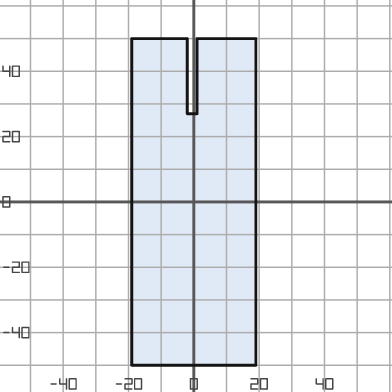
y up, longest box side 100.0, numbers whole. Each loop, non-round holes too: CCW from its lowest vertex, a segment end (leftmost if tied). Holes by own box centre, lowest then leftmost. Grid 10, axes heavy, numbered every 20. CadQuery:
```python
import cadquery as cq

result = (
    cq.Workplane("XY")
    .moveTo(-19.0, -50.0)
    .lineTo(19.0, -50.0)
    .lineTo(19.0, 50.0)
    .lineTo(1.0, 50.0)
    .lineTo(1.0, 27.0)
    .lineTo(-2.0, 27.0)
    .lineTo(-2.0, 50.0)
    .lineTo(-19.0, 50.0)
    .close()
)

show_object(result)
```